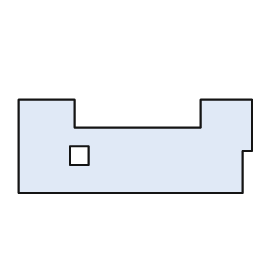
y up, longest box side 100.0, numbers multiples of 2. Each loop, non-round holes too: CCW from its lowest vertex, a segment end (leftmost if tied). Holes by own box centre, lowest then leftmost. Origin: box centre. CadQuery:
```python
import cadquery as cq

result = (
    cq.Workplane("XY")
    .moveTo(-50.0, -20.0)
    .lineTo(46.0, -20.0)
    .lineTo(46.0, -2.0)
    .lineTo(50.0, -2.0)
    .lineTo(50.0, 20.0)
    .lineTo(28.0, 20.0)
    .lineTo(28.0, 8.0)
    .lineTo(-26.0, 8.0)
    .lineTo(-26.0, 20.0)
    .lineTo(-50.0, 20.0)
    .close()
    .moveTo(-28.0, -8.0)
    .lineTo(-20.0, -8.0)
    .lineTo(-20.0, 0.0)
    .lineTo(-28.0, 0.0)
    .close()
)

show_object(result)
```